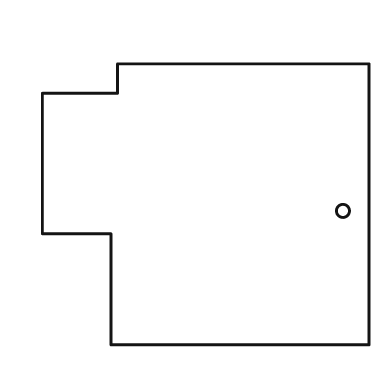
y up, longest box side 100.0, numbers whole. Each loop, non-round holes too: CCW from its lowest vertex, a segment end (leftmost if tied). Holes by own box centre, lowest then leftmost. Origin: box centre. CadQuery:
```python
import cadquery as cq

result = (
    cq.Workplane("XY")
    .moveTo(-29.0, -43.0)
    .lineTo(50.0, -43.0)
    .lineTo(50.0, 43.0)
    .lineTo(-27.0, 43.0)
    .lineTo(-27.0, 34.0)
    .lineTo(-50.0, 34.0)
    .lineTo(-50.0, -9.0)
    .lineTo(-29.0, -9.0)
    .close()
    .moveTo(42.0, -2.0)
    .circle(2.0)
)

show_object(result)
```